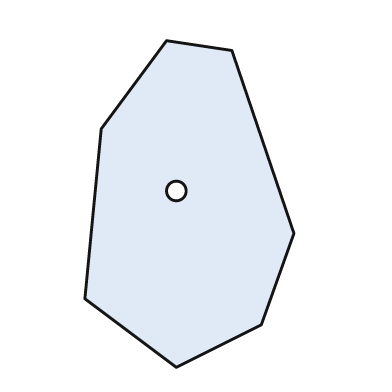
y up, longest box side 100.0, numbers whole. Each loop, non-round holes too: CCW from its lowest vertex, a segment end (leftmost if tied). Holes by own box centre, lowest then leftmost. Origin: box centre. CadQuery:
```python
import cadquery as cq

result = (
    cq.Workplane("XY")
    .moveTo(-4.0, -50.0)
    .lineTo(22.0, -37.0)
    .lineTo(32.0, -9.0)
    .lineTo(13.0, 47.0)
    .lineTo(-7.0, 50.0)
    .lineTo(-27.0, 23.0)
    .lineTo(-32.0, -29.0)
    .close()
    .moveTo(-4.0, 4.0)
    .circle(3.0)
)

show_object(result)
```